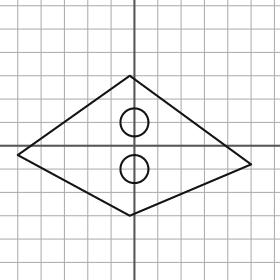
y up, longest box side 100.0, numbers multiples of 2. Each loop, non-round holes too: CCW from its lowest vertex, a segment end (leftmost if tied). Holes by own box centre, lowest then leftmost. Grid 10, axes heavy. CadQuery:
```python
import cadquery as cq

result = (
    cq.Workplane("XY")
    .moveTo(-2.0, -30.0)
    .lineTo(50.0, -8.0)
    .lineTo(-2.0, 30.0)
    .lineTo(-50.0, -4.0)
    .close()
    .moveTo(0.0, -10.0)
    .circle(6.0)
    .moveTo(0.0, 10.0)
    .circle(6.0)
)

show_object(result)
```